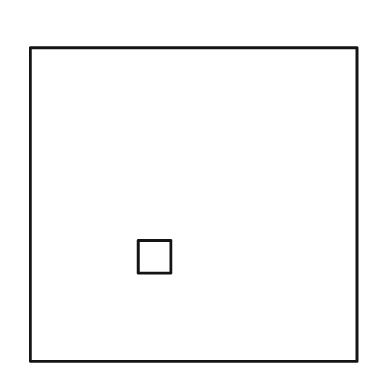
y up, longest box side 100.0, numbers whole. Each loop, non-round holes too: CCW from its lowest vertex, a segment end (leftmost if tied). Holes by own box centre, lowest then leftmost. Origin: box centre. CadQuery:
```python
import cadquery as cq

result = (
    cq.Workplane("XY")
    .moveTo(-50.0, -48.0)
    .lineTo(50.0, -48.0)
    .lineTo(50.0, 48.0)
    .lineTo(-50.0, 48.0)
    .close()
    .moveTo(-17.0, -21.0)
    .lineTo(-7.0, -21.0)
    .lineTo(-7.0, -11.0)
    .lineTo(-17.0, -11.0)
    .close()
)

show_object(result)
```